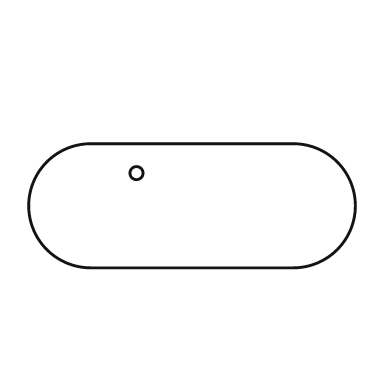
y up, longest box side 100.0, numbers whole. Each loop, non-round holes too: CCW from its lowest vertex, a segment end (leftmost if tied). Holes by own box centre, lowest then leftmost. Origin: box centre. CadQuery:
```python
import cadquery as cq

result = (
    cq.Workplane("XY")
    .moveTo(-31.0, -19.0)
    .lineTo(31.0, -19.0)
    .threePointArc((50.0, 0.0), (31.0, 19.0))
    .lineTo(-31.0, 19.0)
    .threePointArc((-50.0, 0.0), (-31.0, -19.0))
    .close()
    .moveTo(-17.0, 10.0)
    .circle(2.0)
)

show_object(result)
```